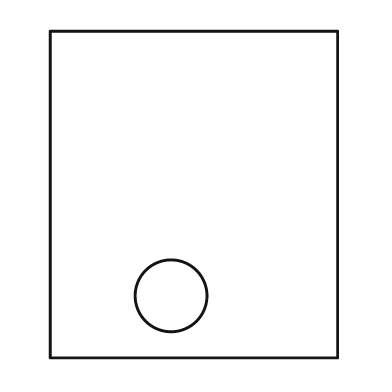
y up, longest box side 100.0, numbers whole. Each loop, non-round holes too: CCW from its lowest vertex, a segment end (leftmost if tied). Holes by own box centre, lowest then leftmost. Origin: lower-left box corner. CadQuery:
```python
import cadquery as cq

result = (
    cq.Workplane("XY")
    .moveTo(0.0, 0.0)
    .lineTo(88.0, 0.0)
    .lineTo(88.0, 100.0)
    .lineTo(0.0, 100.0)
    .close()
    .moveTo(37.0, 19.0)
    .circle(11.0)
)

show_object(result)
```